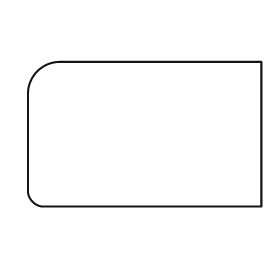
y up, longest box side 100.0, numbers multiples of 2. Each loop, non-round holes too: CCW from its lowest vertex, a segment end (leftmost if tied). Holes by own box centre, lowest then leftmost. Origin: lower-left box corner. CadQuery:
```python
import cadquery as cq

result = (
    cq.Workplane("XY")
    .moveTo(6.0, 0.0)
    .lineTo(100.0, 0.0)
    .lineTo(100.0, 62.0)
    .lineTo(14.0, 62.0)
    .threePointArc((4.0, 58.0), (0.0, 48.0))
    .lineTo(0.0, 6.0)
    .threePointArc((2.0, 2.0), (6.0, 0.0))
    .close()
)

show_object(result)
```